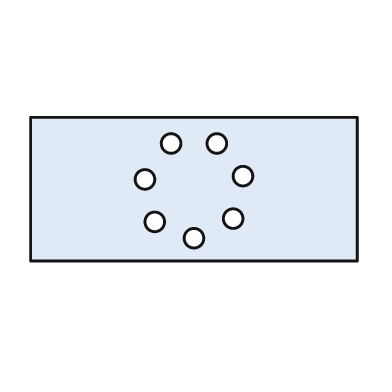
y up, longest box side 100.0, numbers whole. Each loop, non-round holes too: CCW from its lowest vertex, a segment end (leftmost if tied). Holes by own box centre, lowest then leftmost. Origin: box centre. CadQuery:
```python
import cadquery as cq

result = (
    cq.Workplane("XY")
    .moveTo(-50.0, -22.0)
    .lineTo(50.0, -22.0)
    .lineTo(50.0, 22.0)
    .lineTo(-50.0, 22.0)
    .close()
    .moveTo(0.0, -15.0)
    .circle(3.0)
    .moveTo(-12.0, -10.0)
    .circle(3.0)
    .moveTo(12.0, -9.0)
    .circle(3.0)
    .moveTo(-15.0, 3.0)
    .circle(3.0)
    .moveTo(15.0, 4.0)
    .circle(3.0)
    .moveTo(-7.0, 14.0)
    .circle(3.0)
    .moveTo(7.0, 14.0)
    .circle(3.0)
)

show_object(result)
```